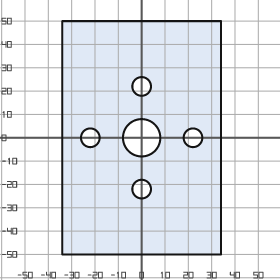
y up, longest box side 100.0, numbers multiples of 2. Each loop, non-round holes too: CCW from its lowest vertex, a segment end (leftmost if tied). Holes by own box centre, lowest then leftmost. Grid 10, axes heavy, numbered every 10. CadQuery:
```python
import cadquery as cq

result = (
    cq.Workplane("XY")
    .moveTo(-34.0, -50.0)
    .lineTo(34.0, -50.0)
    .lineTo(34.0, 50.0)
    .lineTo(-34.0, 50.0)
    .close()
    .moveTo(0.0, -22.0)
    .circle(4.0)
    .moveTo(-22.0, 0.0)
    .circle(4.0)
    .moveTo(0.0, 0.0)
    .circle(8.0)
    .moveTo(22.0, 0.0)
    .circle(4.0)
    .moveTo(0.0, 22.0)
    .circle(4.0)
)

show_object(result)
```